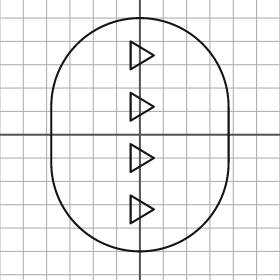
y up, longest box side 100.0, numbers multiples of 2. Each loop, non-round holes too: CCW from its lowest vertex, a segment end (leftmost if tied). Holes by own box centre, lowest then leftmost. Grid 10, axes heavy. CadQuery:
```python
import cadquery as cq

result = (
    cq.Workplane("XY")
    .moveTo(-38.0, -12.0)
    .threePointArc((0.0, -50.0), (38.0, -12.0))
    .lineTo(38.0, 12.0)
    .threePointArc((0.0, 50.0), (-38.0, 12.0))
    .close()
    .moveTo(-4.0, -38.0)
    .lineTo(6.0, -32.0)
    .lineTo(-4.0, -26.0)
    .close()
    .moveTo(-4.0, -16.0)
    .lineTo(6.0, -10.0)
    .lineTo(-4.0, -4.0)
    .close()
    .moveTo(-4.0, 6.0)
    .lineTo(6.0, 12.0)
    .lineTo(-4.0, 18.0)
    .close()
    .moveTo(-4.0, 28.0)
    .lineTo(6.0, 34.0)
    .lineTo(-4.0, 40.0)
    .close()
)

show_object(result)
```